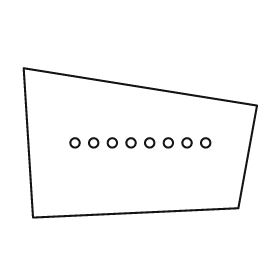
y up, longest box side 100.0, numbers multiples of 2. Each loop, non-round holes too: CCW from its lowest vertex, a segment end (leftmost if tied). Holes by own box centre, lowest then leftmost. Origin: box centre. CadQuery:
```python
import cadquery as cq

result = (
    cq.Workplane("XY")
    .moveTo(-46.0, -32.0)
    .lineTo(42.0, -28.0)
    .lineTo(50.0, 16.0)
    .lineTo(-50.0, 32.0)
    .close()
    .moveTo(-28.0, 0.0)
    .circle(2.0)
    .moveTo(-20.0, 0.0)
    .circle(2.0)
    .moveTo(-12.0, 0.0)
    .circle(2.0)
    .moveTo(-4.0, 0.0)
    .circle(2.0)
    .moveTo(4.0, 0.0)
    .circle(2.0)
    .moveTo(12.0, 0.0)
    .circle(2.0)
    .moveTo(20.0, 0.0)
    .circle(2.0)
    .moveTo(28.0, 0.0)
    .circle(2.0)
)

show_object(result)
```